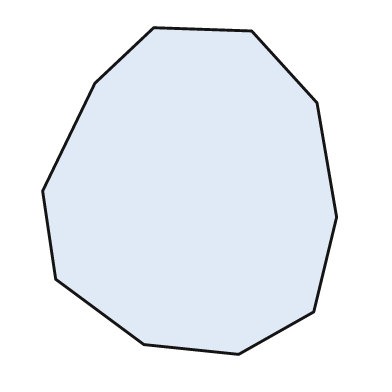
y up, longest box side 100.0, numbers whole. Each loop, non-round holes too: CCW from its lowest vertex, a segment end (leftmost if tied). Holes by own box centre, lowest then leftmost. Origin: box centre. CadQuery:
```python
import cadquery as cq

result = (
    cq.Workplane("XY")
    .moveTo(15.0, -50.0)
    .lineTo(38.0, -37.0)
    .lineTo(45.0, -8.0)
    .lineTo(39.0, 27.0)
    .lineTo(19.0, 49.0)
    .lineTo(-11.0, 50.0)
    .lineTo(-29.0, 33.0)
    .lineTo(-45.0, 0.0)
    .lineTo(-41.0, -27.0)
    .lineTo(-14.0, -47.0)
    .close()
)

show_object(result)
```